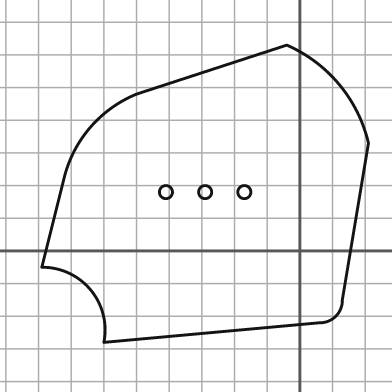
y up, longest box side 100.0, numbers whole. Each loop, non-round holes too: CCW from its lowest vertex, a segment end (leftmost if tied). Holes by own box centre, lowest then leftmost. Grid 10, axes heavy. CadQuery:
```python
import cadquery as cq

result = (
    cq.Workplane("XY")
    .moveTo(-60.0, -28.0)
    .lineTo(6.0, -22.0)
    .threePointArc((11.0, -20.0), (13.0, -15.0))
    .lineTo(21.0, 33.0)
    .threePointArc((12.0, 51.0), (-4.0, 63.0))
    .lineTo(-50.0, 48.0)
    .threePointArc((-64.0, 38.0), (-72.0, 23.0))
    .lineTo(-79.0, -5.0)
    .threePointArc((-64.0, -12.0), (-60.0, -28.0))
    .close()
    .moveTo(-41.0, 18.0)
    .circle(2.0)
    .moveTo(-29.0, 18.0)
    .circle(2.0)
    .moveTo(-17.0, 18.0)
    .circle(2.0)
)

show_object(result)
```